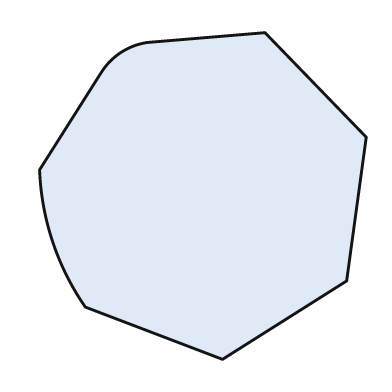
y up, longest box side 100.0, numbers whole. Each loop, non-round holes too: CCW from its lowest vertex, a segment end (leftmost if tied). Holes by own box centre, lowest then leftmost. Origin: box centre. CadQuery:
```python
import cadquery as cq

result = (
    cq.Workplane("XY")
    .moveTo(6.0, -50.0)
    .lineTo(44.0, -26.0)
    .lineTo(50.0, 18.0)
    .lineTo(19.0, 50.0)
    .lineTo(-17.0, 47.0)
    .threePointArc((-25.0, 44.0), (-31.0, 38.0))
    .lineTo(-50.0, 8.0)
    .threePointArc((-46.0, -14.0), (-36.0, -34.0))
    .close()
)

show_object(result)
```